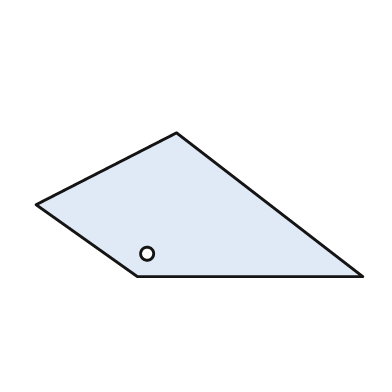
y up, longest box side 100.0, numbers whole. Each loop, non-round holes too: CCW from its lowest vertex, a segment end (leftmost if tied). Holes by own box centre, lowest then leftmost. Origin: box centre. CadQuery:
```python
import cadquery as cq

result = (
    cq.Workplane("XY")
    .moveTo(-19.0, -22.0)
    .lineTo(50.0, -22.0)
    .lineTo(-7.0, 22.0)
    .lineTo(-50.0, 0.0)
    .close()
    .moveTo(-16.0, -15.0)
    .circle(2.0)
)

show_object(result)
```